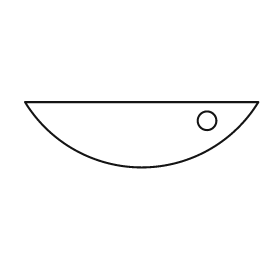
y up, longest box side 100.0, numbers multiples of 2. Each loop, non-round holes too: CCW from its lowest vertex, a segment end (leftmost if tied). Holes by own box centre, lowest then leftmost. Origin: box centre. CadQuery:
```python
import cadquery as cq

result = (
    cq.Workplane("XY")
    .moveTo(-50.0, 14.0)
    .threePointArc((0.0, -14.0), (50.0, 14.0))
    .close()
    .moveTo(28.0, 6.0)
    .circle(4.0)
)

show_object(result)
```